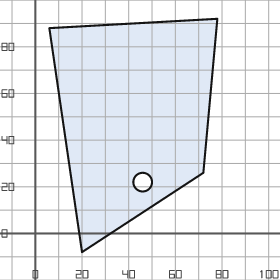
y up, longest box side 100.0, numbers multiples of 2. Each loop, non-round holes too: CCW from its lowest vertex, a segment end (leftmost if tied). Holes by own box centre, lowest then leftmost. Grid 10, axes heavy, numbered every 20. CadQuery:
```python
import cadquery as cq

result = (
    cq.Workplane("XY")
    .moveTo(20.0, -8.0)
    .lineTo(72.0, 26.0)
    .lineTo(78.0, 92.0)
    .lineTo(6.0, 88.0)
    .close()
    .moveTo(46.0, 22.0)
    .circle(4.0)
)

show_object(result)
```